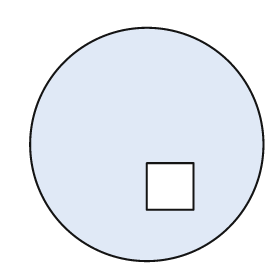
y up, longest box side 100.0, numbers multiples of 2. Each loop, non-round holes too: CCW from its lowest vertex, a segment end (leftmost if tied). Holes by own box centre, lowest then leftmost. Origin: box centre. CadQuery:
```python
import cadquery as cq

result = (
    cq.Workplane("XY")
    .moveTo(0.0, 0.0)
    .circle(50.0)
    .moveTo(0.0, -28.0)
    .lineTo(20.0, -28.0)
    .lineTo(20.0, -8.0)
    .lineTo(0.0, -8.0)
    .close()
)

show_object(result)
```